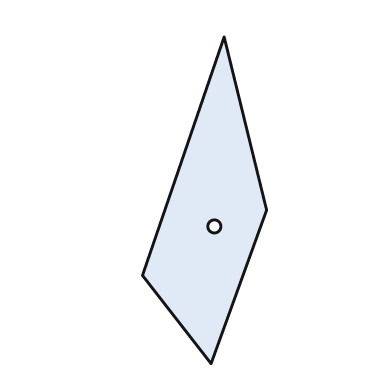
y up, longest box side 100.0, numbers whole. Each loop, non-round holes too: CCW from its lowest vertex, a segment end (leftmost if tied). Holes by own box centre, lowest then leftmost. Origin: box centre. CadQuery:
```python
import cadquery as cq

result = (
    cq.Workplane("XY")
    .moveTo(2.0, -50.0)
    .lineTo(19.0, -3.0)
    .lineTo(6.0, 50.0)
    .lineTo(-19.0, -23.0)
    .close()
    .moveTo(3.0, -8.0)
    .circle(2.0)
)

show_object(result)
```